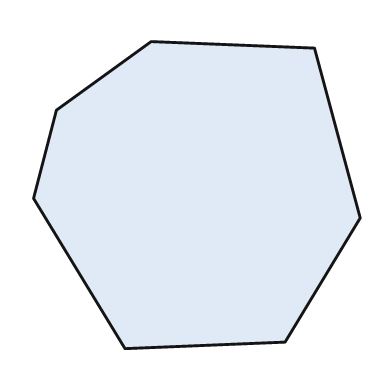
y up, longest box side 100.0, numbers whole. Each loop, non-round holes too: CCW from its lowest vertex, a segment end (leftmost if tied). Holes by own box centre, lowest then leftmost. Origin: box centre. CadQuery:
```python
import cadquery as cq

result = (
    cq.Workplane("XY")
    .moveTo(-22.0, -47.0)
    .lineTo(27.0, -45.0)
    .lineTo(50.0, -7.0)
    .lineTo(36.0, 45.0)
    .lineTo(-14.0, 47.0)
    .lineTo(-43.0, 26.0)
    .lineTo(-50.0, -1.0)
    .close()
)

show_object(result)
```